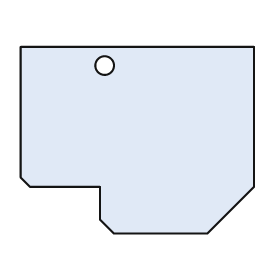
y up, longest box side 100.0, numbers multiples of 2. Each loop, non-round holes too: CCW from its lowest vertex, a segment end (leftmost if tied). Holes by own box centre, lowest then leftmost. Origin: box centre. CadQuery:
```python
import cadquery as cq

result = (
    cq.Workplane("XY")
    .moveTo(-10.0, -40.0)
    .lineTo(30.0, -40.0)
    .lineTo(50.0, -20.0)
    .lineTo(50.0, 40.0)
    .lineTo(-50.0, 40.0)
    .lineTo(-50.0, -16.0)
    .lineTo(-46.0, -20.0)
    .lineTo(-16.0, -20.0)
    .lineTo(-16.0, -34.0)
    .close()
    .moveTo(-14.0, 32.0)
    .circle(4.0)
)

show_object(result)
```